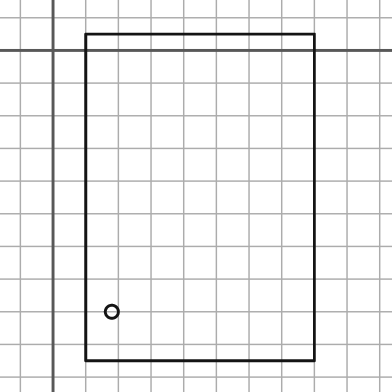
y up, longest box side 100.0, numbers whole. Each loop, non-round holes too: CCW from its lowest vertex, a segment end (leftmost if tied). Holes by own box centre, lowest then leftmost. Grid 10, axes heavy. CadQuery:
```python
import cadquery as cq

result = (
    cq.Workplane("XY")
    .moveTo(10.0, -95.0)
    .lineTo(80.0, -95.0)
    .lineTo(80.0, 5.0)
    .lineTo(10.0, 5.0)
    .close()
    .moveTo(18.0, -80.0)
    .circle(2.0)
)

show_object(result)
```